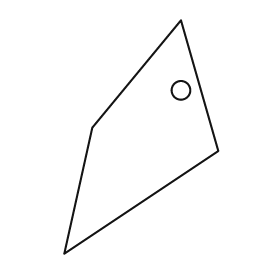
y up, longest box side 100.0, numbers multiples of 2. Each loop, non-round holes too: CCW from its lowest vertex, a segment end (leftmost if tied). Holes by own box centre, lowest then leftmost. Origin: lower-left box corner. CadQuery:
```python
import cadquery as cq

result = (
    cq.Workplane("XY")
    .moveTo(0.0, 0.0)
    .lineTo(66.0, 44.0)
    .lineTo(50.0, 100.0)
    .lineTo(12.0, 54.0)
    .close()
    .moveTo(50.0, 70.0)
    .circle(4.0)
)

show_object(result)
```